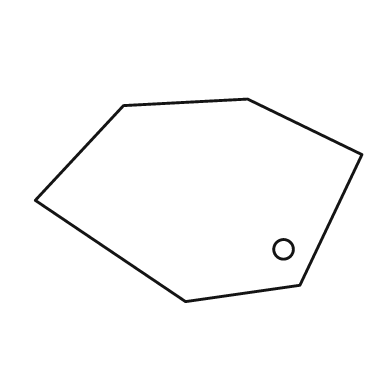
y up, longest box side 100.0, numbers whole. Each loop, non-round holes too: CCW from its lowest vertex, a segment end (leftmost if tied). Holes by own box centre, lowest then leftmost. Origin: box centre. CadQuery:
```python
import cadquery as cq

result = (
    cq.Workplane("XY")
    .moveTo(-4.0, -31.0)
    .lineTo(31.0, -26.0)
    .lineTo(50.0, 14.0)
    .lineTo(15.0, 31.0)
    .lineTo(-23.0, 29.0)
    .lineTo(-50.0, 0.0)
    .close()
    .moveTo(26.0, -15.0)
    .circle(3.0)
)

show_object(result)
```